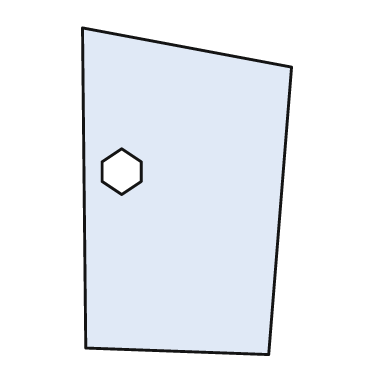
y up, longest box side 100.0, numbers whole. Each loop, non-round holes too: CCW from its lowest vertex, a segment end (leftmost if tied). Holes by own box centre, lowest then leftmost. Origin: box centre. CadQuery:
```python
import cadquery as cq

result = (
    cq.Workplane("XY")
    .moveTo(25.0, -50.0)
    .lineTo(32.0, 38.0)
    .lineTo(-32.0, 50.0)
    .lineTo(-31.0, -48.0)
    .close()
    .moveTo(-20.0, -1.0)
    .lineTo(-14.0, 3.0)
    .lineTo(-14.0, 9.0)
    .lineTo(-20.0, 13.0)
    .lineTo(-26.0, 9.0)
    .lineTo(-26.0, 3.0)
    .close()
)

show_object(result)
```